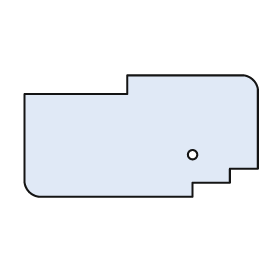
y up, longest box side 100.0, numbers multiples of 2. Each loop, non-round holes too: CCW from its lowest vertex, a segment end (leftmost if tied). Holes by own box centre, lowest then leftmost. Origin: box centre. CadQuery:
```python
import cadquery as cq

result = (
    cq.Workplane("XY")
    .moveTo(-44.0, -26.0)
    .lineTo(22.0, -26.0)
    .lineTo(22.0, -20.0)
    .lineTo(38.0, -20.0)
    .lineTo(38.0, -14.0)
    .lineTo(50.0, -14.0)
    .lineTo(50.0, 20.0)
    .threePointArc((48.0, 24.0), (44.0, 26.0))
    .lineTo(-6.0, 26.0)
    .lineTo(-6.0, 18.0)
    .lineTo(-50.0, 18.0)
    .lineTo(-50.0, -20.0)
    .threePointArc((-48.0, -24.0), (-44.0, -26.0))
    .close()
    .moveTo(22.0, -8.0)
    .circle(2.0)
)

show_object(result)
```